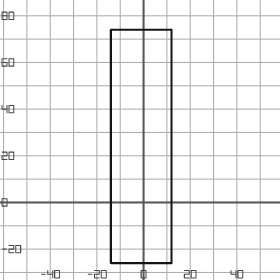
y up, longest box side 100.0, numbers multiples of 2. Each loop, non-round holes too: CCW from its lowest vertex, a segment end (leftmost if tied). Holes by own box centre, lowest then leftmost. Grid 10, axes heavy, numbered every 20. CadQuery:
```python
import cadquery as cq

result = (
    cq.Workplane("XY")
    .moveTo(-14.0, -26.0)
    .lineTo(12.0, -26.0)
    .lineTo(12.0, 74.0)
    .lineTo(-14.0, 74.0)
    .close()
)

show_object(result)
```